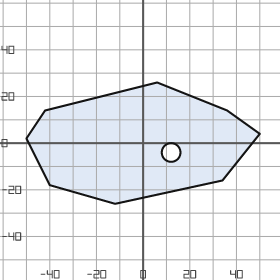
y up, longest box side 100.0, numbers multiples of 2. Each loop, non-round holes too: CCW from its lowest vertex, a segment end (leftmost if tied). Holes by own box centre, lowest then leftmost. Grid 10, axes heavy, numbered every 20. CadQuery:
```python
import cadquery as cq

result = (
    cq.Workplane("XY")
    .moveTo(-12.0, -26.0)
    .lineTo(34.0, -16.0)
    .lineTo(50.0, 4.0)
    .lineTo(36.0, 14.0)
    .lineTo(6.0, 26.0)
    .lineTo(-42.0, 14.0)
    .lineTo(-50.0, 2.0)
    .lineTo(-40.0, -18.0)
    .close()
    .moveTo(12.0, -4.0)
    .circle(4.0)
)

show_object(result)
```